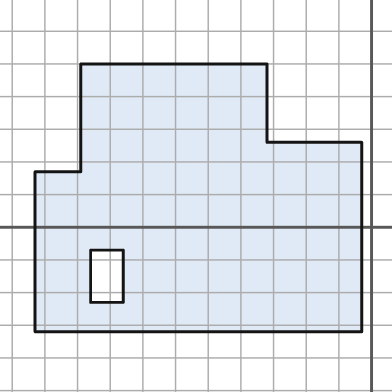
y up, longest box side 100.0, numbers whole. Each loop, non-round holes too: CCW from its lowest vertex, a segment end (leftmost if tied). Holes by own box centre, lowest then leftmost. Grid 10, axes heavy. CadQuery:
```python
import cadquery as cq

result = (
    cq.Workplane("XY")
    .moveTo(-103.0, -32.0)
    .lineTo(-3.0, -32.0)
    .lineTo(-3.0, 26.0)
    .lineTo(-32.0, 26.0)
    .lineTo(-32.0, 50.0)
    .lineTo(-89.0, 50.0)
    .lineTo(-89.0, 17.0)
    .lineTo(-103.0, 17.0)
    .close()
    .moveTo(-86.0, -23.0)
    .lineTo(-76.0, -23.0)
    .lineTo(-76.0, -7.0)
    .lineTo(-86.0, -7.0)
    .close()
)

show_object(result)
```